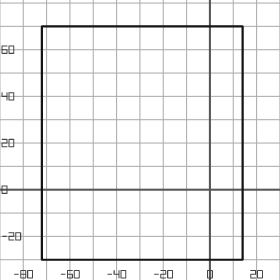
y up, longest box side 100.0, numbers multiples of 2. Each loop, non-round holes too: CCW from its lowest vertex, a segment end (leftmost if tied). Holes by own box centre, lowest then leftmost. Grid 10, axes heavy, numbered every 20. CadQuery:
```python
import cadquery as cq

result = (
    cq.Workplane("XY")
    .moveTo(-72.0, -30.0)
    .lineTo(14.0, -30.0)
    .lineTo(14.0, 70.0)
    .lineTo(-72.0, 70.0)
    .close()
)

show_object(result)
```